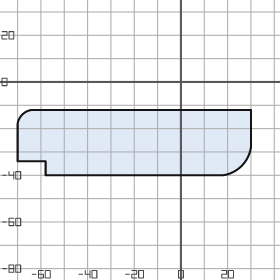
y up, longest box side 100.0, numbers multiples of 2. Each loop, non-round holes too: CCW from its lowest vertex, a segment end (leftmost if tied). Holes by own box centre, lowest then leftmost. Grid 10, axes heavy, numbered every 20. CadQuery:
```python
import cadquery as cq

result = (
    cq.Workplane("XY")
    .moveTo(-58.0, -40.0)
    .lineTo(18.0, -40.0)
    .threePointArc((26.0, -36.0), (30.0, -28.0))
    .lineTo(30.0, -12.0)
    .lineTo(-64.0, -12.0)
    .threePointArc((-68.0, -14.0), (-70.0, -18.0))
    .lineTo(-70.0, -34.0)
    .lineTo(-58.0, -34.0)
    .close()
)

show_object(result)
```